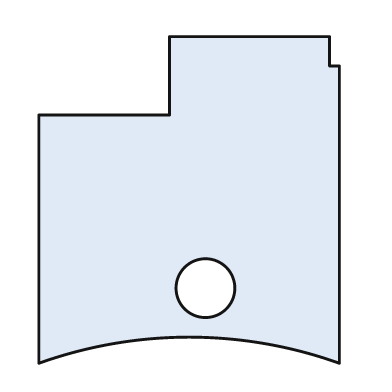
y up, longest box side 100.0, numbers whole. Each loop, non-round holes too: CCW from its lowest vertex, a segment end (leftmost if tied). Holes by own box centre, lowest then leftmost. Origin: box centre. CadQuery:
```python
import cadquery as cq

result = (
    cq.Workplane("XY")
    .moveTo(-46.0, -50.0)
    .threePointArc((0.0, -42.0), (46.0, -50.0))
    .lineTo(46.0, 41.0)
    .lineTo(43.0, 41.0)
    .lineTo(43.0, 50.0)
    .lineTo(-6.0, 50.0)
    .lineTo(-6.0, 26.0)
    .lineTo(-46.0, 26.0)
    .close()
    .moveTo(5.0, -27.0)
    .circle(9.0)
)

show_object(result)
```